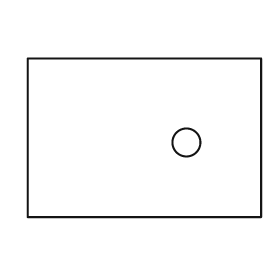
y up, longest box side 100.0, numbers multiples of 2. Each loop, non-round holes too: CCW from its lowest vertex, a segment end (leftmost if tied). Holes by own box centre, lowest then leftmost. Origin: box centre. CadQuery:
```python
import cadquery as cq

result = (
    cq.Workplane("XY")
    .moveTo(-50.0, -34.0)
    .lineTo(50.0, -34.0)
    .lineTo(50.0, 34.0)
    .lineTo(-50.0, 34.0)
    .close()
    .moveTo(18.0, -2.0)
    .circle(6.0)
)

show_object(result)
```